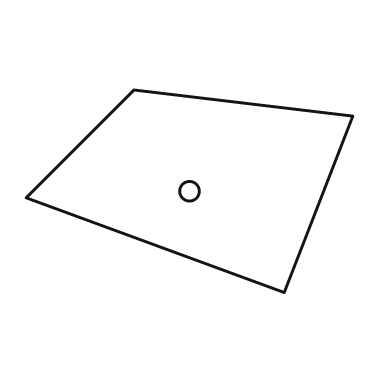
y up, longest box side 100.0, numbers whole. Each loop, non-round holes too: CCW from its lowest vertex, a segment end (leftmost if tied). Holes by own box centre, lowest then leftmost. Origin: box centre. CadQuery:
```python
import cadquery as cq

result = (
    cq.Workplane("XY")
    .moveTo(29.0, -31.0)
    .lineTo(50.0, 23.0)
    .lineTo(-17.0, 31.0)
    .lineTo(-50.0, -2.0)
    .close()
    .moveTo(0.0, 0.0)
    .circle(3.0)
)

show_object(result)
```